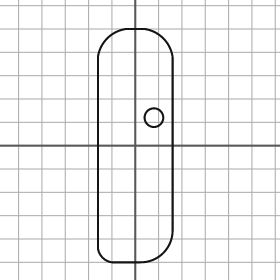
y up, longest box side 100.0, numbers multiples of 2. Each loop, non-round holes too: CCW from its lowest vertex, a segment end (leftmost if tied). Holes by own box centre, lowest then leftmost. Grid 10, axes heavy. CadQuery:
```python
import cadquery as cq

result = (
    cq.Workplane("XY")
    .moveTo(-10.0, -50.0)
    .lineTo(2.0, -50.0)
    .threePointArc((12.0, -46.0), (16.0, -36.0))
    .lineTo(16.0, 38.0)
    .threePointArc((12.0, 46.0), (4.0, 50.0))
    .lineTo(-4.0, 50.0)
    .threePointArc((-12.0, 46.0), (-16.0, 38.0))
    .lineTo(-16.0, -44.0)
    .threePointArc((-14.0, -48.0), (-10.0, -50.0))
    .close()
    .moveTo(8.0, 12.0)
    .circle(4.0)
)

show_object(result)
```